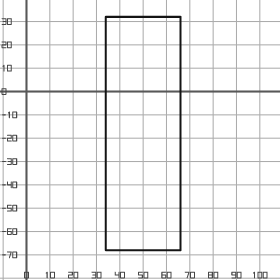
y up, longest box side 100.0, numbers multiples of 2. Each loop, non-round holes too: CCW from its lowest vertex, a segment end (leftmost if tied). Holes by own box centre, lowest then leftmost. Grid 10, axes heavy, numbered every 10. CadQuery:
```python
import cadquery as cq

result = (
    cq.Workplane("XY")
    .moveTo(34.0, -68.0)
    .lineTo(66.0, -68.0)
    .lineTo(66.0, 32.0)
    .lineTo(34.0, 32.0)
    .close()
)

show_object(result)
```